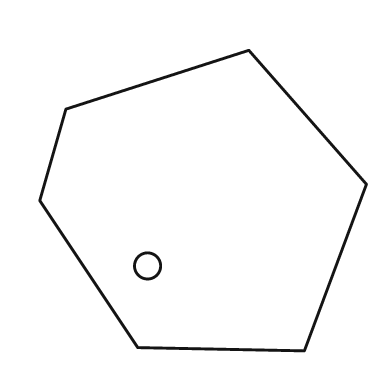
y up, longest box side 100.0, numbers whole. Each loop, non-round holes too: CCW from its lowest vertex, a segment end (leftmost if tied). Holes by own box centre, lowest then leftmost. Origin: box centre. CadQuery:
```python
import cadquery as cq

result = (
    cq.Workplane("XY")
    .moveTo(31.0, -46.0)
    .lineTo(50.0, 5.0)
    .lineTo(14.0, 46.0)
    .lineTo(-42.0, 28.0)
    .lineTo(-50.0, 0.0)
    .lineTo(-20.0, -45.0)
    .close()
    .moveTo(-17.0, -20.0)
    .circle(4.0)
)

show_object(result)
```